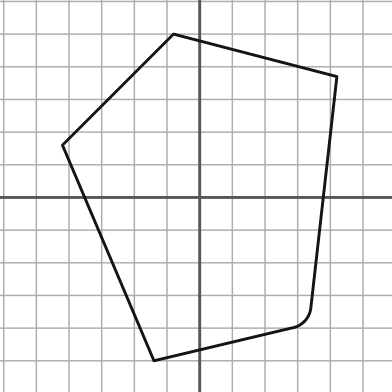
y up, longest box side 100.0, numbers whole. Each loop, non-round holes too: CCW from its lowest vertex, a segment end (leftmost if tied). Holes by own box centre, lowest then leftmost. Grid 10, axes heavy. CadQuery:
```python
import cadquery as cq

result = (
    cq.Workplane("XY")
    .moveTo(-14.0, -50.0)
    .lineTo(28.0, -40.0)
    .threePointArc((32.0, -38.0), (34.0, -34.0))
    .lineTo(42.0, 37.0)
    .lineTo(-8.0, 50.0)
    .lineTo(-42.0, 16.0)
    .close()
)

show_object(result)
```